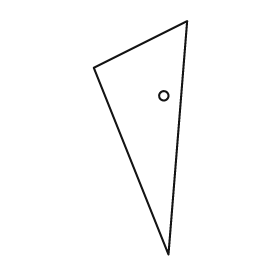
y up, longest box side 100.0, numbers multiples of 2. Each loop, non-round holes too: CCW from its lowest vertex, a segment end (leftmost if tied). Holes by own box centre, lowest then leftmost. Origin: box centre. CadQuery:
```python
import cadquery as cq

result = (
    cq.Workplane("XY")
    .moveTo(12.0, -50.0)
    .lineTo(20.0, 50.0)
    .lineTo(-20.0, 30.0)
    .close()
    .moveTo(10.0, 18.0)
    .circle(2.0)
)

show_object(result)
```